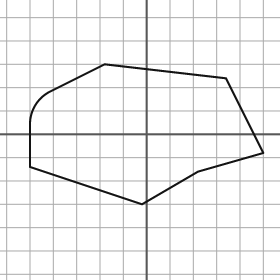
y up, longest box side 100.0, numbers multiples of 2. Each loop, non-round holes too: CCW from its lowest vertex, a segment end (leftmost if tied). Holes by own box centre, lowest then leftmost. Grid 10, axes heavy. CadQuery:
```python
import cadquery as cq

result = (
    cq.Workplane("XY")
    .moveTo(-2.0, -30.0)
    .lineTo(22.0, -16.0)
    .lineTo(50.0, -8.0)
    .lineTo(34.0, 24.0)
    .lineTo(-18.0, 30.0)
    .lineTo(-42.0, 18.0)
    .threePointArc((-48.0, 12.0), (-50.0, 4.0))
    .lineTo(-50.0, -14.0)
    .close()
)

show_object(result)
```